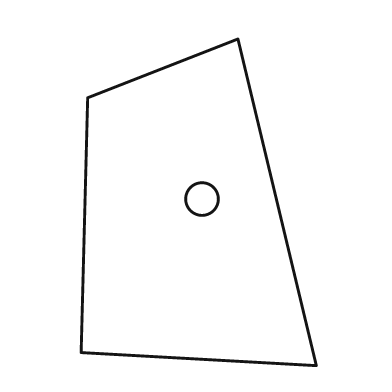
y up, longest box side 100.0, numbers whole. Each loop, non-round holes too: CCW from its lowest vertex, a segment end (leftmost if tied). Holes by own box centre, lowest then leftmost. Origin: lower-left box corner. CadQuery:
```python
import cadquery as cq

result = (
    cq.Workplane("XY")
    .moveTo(72.0, 0.0)
    .lineTo(48.0, 100.0)
    .lineTo(2.0, 82.0)
    .lineTo(0.0, 4.0)
    .close()
    .moveTo(37.0, 51.0)
    .circle(5.0)
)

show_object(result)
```